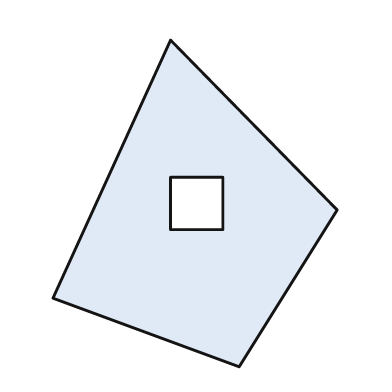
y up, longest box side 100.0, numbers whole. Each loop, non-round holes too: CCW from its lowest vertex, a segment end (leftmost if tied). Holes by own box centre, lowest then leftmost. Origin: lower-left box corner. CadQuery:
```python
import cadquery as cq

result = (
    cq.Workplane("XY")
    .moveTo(57.0, 0.0)
    .lineTo(87.0, 48.0)
    .lineTo(36.0, 100.0)
    .lineTo(0.0, 21.0)
    .close()
    .moveTo(36.0, 42.0)
    .lineTo(52.0, 42.0)
    .lineTo(52.0, 58.0)
    .lineTo(36.0, 58.0)
    .close()
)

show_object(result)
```